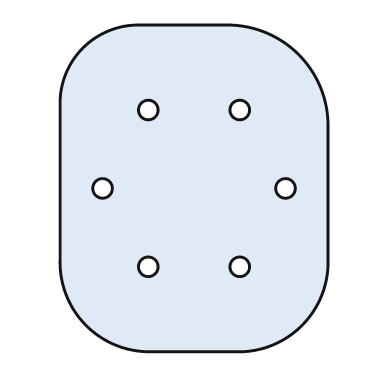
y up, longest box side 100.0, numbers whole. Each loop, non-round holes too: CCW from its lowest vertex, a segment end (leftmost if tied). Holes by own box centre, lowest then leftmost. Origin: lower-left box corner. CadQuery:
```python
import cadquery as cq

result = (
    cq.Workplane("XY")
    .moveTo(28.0, 0.0)
    .lineTo(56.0, 0.0)
    .threePointArc((74.0, 8.0), (82.0, 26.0))
    .lineTo(82.0, 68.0)
    .threePointArc((73.0, 91.0), (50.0, 100.0))
    .lineTo(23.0, 100.0)
    .threePointArc((7.0, 93.0), (0.0, 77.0))
    .lineTo(0.0, 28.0)
    .threePointArc((8.0, 8.0), (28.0, 0.0))
    .close()
    .moveTo(27.0, 26.0)
    .circle(3.0)
    .moveTo(55.0, 26.0)
    .circle(3.0)
    .moveTo(13.0, 50.0)
    .circle(3.0)
    .moveTo(69.0, 50.0)
    .circle(3.0)
    .moveTo(27.0, 74.0)
    .circle(3.0)
    .moveTo(55.0, 74.0)
    .circle(3.0)
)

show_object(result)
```